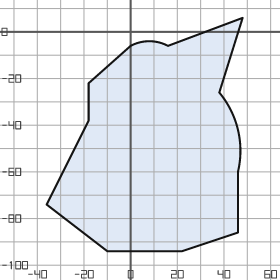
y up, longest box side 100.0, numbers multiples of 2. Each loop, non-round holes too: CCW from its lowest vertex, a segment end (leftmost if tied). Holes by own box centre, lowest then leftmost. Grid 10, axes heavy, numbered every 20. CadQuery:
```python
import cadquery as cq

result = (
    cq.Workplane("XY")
    .moveTo(-10.0, -94.0)
    .lineTo(22.0, -94.0)
    .lineTo(46.0, -86.0)
    .lineTo(46.0, -60.0)
    .threePointArc((46.0, -42.0), (38.0, -26.0))
    .lineTo(48.0, 6.0)
    .lineTo(16.0, -6.0)
    .threePointArc((8.0, -4.0), (0.0, -6.0))
    .lineTo(-18.0, -22.0)
    .lineTo(-18.0, -38.0)
    .lineTo(-36.0, -74.0)
    .close()
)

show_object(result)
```